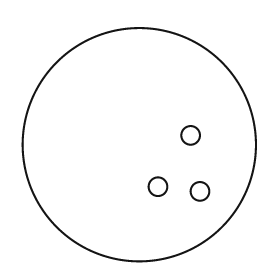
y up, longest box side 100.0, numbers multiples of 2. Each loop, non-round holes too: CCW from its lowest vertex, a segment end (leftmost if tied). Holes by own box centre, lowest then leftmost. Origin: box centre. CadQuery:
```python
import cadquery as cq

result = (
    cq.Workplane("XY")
    .moveTo(0.0, 0.0)
    .circle(50.0)
    .moveTo(26.0, -20.0)
    .circle(4.0)
    .moveTo(8.0, -18.0)
    .circle(4.0)
    .moveTo(22.0, 4.0)
    .circle(4.0)
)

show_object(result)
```